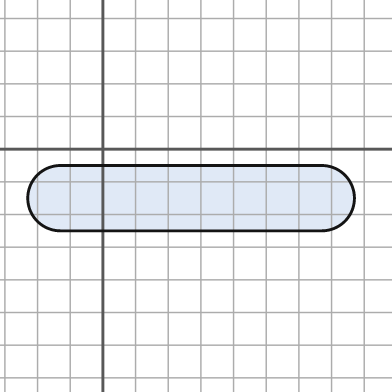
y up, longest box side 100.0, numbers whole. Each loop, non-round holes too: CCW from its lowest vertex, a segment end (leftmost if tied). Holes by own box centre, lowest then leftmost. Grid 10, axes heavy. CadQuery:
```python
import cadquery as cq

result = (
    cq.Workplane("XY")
    .moveTo(-13.0, -25.0)
    .lineTo(67.0, -25.0)
    .threePointArc((77.0, -15.0), (67.0, -5.0))
    .lineTo(-13.0, -5.0)
    .threePointArc((-23.0, -15.0), (-13.0, -25.0))
    .close()
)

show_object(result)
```